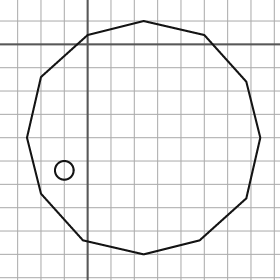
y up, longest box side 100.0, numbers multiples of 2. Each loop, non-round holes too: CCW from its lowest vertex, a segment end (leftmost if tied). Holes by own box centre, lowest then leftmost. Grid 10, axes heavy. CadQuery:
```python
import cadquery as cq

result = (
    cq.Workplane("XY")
    .moveTo(24.0, -90.0)
    .lineTo(48.0, -84.0)
    .lineTo(68.0, -66.0)
    .lineTo(74.0, -40.0)
    .lineTo(68.0, -16.0)
    .lineTo(50.0, 4.0)
    .lineTo(24.0, 10.0)
    .lineTo(0.0, 4.0)
    .lineTo(-20.0, -14.0)
    .lineTo(-26.0, -40.0)
    .lineTo(-20.0, -64.0)
    .lineTo(-2.0, -84.0)
    .close()
    .moveTo(-10.0, -54.0)
    .circle(4.0)
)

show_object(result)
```